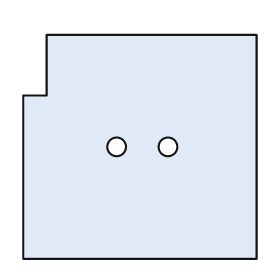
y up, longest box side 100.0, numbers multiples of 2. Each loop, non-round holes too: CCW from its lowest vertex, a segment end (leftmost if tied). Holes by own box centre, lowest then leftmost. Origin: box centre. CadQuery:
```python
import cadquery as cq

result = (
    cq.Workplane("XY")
    .moveTo(-50.0, -48.0)
    .lineTo(50.0, -48.0)
    .lineTo(50.0, 48.0)
    .lineTo(-40.0, 48.0)
    .lineTo(-40.0, 22.0)
    .lineTo(-50.0, 22.0)
    .close()
    .moveTo(-10.0, 0.0)
    .circle(4.0)
    .moveTo(12.0, 0.0)
    .circle(4.0)
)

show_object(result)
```